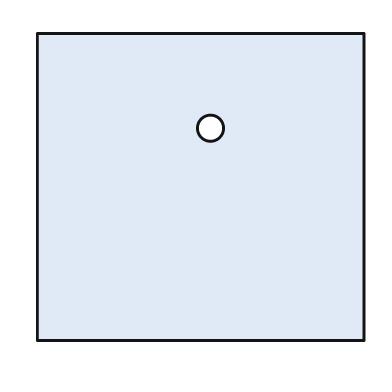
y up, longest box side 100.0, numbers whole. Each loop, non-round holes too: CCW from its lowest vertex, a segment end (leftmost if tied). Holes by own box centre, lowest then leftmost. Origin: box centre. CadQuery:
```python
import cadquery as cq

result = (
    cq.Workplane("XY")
    .moveTo(-50.0, -47.0)
    .lineTo(50.0, -47.0)
    .lineTo(50.0, 47.0)
    .lineTo(-50.0, 47.0)
    .close()
    .moveTo(3.0, 18.0)
    .circle(4.0)
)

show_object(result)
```